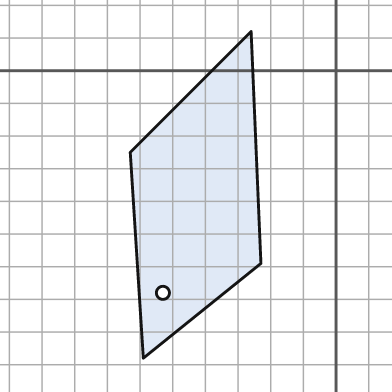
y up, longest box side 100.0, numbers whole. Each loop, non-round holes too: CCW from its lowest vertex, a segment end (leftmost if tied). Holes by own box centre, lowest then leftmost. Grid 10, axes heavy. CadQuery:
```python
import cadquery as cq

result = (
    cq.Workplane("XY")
    .moveTo(-59.0, -88.0)
    .lineTo(-23.0, -59.0)
    .lineTo(-26.0, 12.0)
    .lineTo(-63.0, -25.0)
    .close()
    .moveTo(-53.0, -68.0)
    .circle(2.0)
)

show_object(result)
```